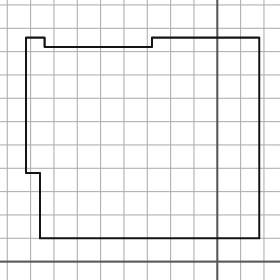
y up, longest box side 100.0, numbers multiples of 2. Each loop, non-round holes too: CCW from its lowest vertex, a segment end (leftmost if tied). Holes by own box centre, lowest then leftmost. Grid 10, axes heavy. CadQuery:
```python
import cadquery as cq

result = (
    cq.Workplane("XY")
    .moveTo(-76.0, 10.0)
    .lineTo(18.0, 10.0)
    .lineTo(18.0, 96.0)
    .lineTo(-28.0, 96.0)
    .lineTo(-28.0, 92.0)
    .lineTo(-74.0, 92.0)
    .lineTo(-74.0, 96.0)
    .lineTo(-82.0, 96.0)
    .lineTo(-82.0, 38.0)
    .lineTo(-76.0, 38.0)
    .close()
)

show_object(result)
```